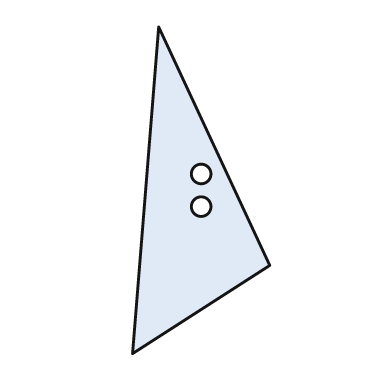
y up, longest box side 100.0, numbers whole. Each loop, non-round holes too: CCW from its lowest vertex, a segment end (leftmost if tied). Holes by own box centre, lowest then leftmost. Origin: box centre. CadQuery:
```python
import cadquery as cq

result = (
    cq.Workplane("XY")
    .moveTo(-21.0, -50.0)
    .lineTo(21.0, -23.0)
    .lineTo(-13.0, 50.0)
    .close()
    .moveTo(0.0, -5.0)
    .circle(3.0)
    .moveTo(0.0, 5.0)
    .circle(3.0)
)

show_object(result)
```